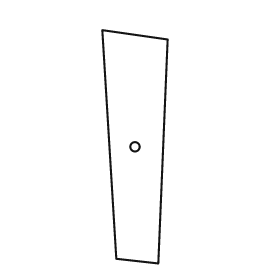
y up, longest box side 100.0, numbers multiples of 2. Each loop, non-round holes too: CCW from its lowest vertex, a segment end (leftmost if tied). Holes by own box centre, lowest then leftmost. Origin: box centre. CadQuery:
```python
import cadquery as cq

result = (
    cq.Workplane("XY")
    .moveTo(10.0, -50.0)
    .lineTo(14.0, 46.0)
    .lineTo(-14.0, 50.0)
    .lineTo(-8.0, -48.0)
    .close()
    .moveTo(0.0, 0.0)
    .circle(2.0)
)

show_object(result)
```